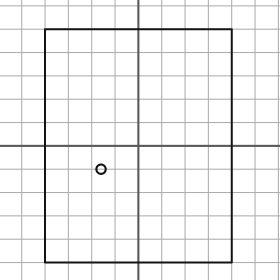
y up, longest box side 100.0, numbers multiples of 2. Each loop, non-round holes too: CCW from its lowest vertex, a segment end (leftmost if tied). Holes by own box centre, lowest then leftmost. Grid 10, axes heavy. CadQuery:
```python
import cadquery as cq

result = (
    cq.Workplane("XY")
    .moveTo(-40.0, -50.0)
    .lineTo(40.0, -50.0)
    .lineTo(40.0, 50.0)
    .lineTo(-40.0, 50.0)
    .close()
    .moveTo(-16.0, -10.0)
    .circle(2.0)
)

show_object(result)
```